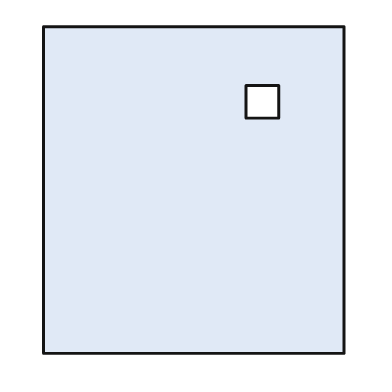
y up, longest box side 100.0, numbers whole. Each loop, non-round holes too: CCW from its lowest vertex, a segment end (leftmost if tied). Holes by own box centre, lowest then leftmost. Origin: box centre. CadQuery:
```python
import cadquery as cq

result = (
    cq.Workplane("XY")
    .moveTo(-46.0, -50.0)
    .lineTo(46.0, -50.0)
    .lineTo(46.0, 50.0)
    .lineTo(-46.0, 50.0)
    .close()
    .moveTo(16.0, 22.0)
    .lineTo(26.0, 22.0)
    .lineTo(26.0, 32.0)
    .lineTo(16.0, 32.0)
    .close()
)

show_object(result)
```